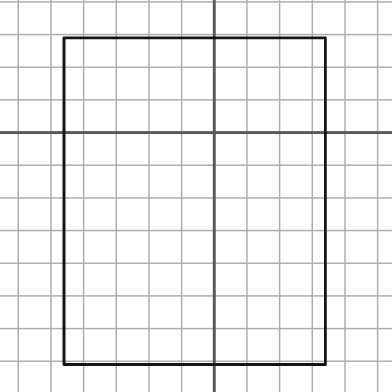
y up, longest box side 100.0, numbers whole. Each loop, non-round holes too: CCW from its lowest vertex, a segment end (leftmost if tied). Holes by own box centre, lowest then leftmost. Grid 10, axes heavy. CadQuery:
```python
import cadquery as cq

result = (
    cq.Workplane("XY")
    .moveTo(-46.0, -71.0)
    .lineTo(34.0, -71.0)
    .lineTo(34.0, 29.0)
    .lineTo(-46.0, 29.0)
    .close()
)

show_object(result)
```